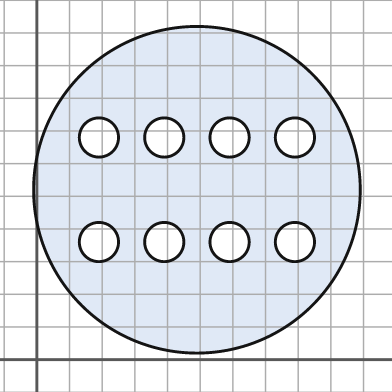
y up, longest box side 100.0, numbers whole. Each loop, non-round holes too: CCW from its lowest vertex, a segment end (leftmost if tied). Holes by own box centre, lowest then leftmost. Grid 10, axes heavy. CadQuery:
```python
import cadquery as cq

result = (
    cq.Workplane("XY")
    .moveTo(49.0, 52.0)
    .circle(50.0)
    .moveTo(19.0, 36.0)
    .circle(6.0)
    .moveTo(39.0, 36.0)
    .circle(6.0)
    .moveTo(59.0, 36.0)
    .circle(6.0)
    .moveTo(79.0, 36.0)
    .circle(6.0)
    .moveTo(19.0, 68.0)
    .circle(6.0)
    .moveTo(39.0, 68.0)
    .circle(6.0)
    .moveTo(59.0, 68.0)
    .circle(6.0)
    .moveTo(79.0, 68.0)
    .circle(6.0)
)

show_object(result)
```